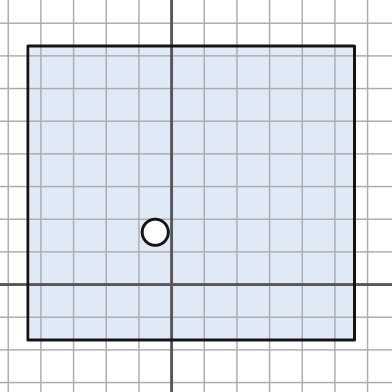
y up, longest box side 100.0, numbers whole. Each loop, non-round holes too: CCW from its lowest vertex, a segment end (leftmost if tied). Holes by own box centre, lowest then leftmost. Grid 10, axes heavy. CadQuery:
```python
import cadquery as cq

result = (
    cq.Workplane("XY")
    .moveTo(-44.0, -17.0)
    .lineTo(56.0, -17.0)
    .lineTo(56.0, 73.0)
    .lineTo(-44.0, 73.0)
    .close()
    .moveTo(-5.0, 16.0)
    .circle(4.0)
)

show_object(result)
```